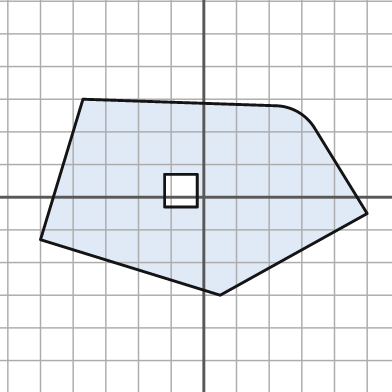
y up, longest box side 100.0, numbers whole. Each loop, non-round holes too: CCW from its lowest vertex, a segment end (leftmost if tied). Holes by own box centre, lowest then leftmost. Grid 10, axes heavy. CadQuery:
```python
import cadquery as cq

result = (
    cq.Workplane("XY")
    .moveTo(5.0, -30.0)
    .lineTo(50.0, -5.0)
    .lineTo(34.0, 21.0)
    .threePointArc((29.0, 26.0), (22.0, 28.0))
    .lineTo(-37.0, 30.0)
    .lineTo(-50.0, -13.0)
    .close()
    .moveTo(-12.0, -3.0)
    .lineTo(-2.0, -3.0)
    .lineTo(-2.0, 7.0)
    .lineTo(-12.0, 7.0)
    .close()
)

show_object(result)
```